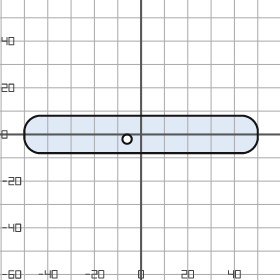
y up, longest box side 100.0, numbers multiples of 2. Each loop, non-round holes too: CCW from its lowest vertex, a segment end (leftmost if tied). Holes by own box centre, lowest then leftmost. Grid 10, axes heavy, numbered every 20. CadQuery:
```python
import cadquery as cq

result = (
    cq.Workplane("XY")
    .moveTo(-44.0, -8.0)
    .lineTo(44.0, -8.0)
    .threePointArc((48.0, -6.0), (50.0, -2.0))
    .lineTo(50.0, 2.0)
    .threePointArc((48.0, 6.0), (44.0, 8.0))
    .lineTo(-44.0, 8.0)
    .threePointArc((-48.0, 6.0), (-50.0, 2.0))
    .lineTo(-50.0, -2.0)
    .threePointArc((-48.0, -6.0), (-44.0, -8.0))
    .close()
    .moveTo(-6.0, -2.0)
    .circle(2.0)
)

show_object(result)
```